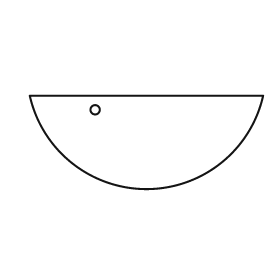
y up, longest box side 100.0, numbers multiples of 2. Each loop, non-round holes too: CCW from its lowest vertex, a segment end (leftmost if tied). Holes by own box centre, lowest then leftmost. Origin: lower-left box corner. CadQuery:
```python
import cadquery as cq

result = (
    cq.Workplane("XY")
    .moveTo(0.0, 40.0)
    .threePointArc((50.0, 0.0), (100.0, 40.0))
    .close()
    .moveTo(28.0, 34.0)
    .circle(2.0)
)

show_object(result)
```